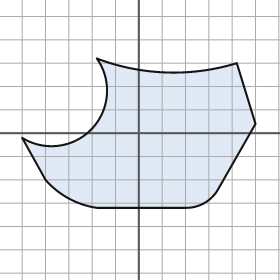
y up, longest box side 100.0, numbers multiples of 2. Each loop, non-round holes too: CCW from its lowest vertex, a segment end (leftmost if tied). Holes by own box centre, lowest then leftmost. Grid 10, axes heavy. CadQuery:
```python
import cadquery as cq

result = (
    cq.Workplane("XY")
    .moveTo(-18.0, -32.0)
    .lineTo(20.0, -32.0)
    .threePointArc((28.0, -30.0), (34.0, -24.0))
    .lineTo(50.0, 4.0)
    .lineTo(42.0, 30.0)
    .threePointArc((12.0, 26.0), (-18.0, 32.0))
    .threePointArc((-20.0, 2.0), (-50.0, -2.0))
    .lineTo(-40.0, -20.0)
    .threePointArc((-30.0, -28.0), (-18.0, -32.0))
    .close()
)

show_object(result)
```